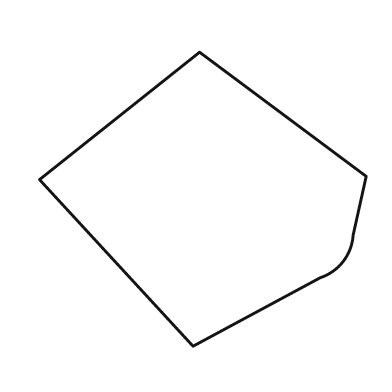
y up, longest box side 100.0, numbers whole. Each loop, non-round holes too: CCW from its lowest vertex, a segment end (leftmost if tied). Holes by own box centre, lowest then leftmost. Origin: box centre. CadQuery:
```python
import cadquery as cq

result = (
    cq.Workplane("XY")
    .moveTo(-3.0, -45.0)
    .lineTo(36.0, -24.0)
    .threePointArc((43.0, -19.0), (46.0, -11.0))
    .lineTo(50.0, 7.0)
    .lineTo(-1.0, 45.0)
    .lineTo(-50.0, 6.0)
    .close()
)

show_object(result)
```